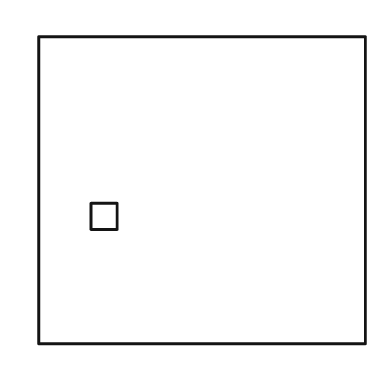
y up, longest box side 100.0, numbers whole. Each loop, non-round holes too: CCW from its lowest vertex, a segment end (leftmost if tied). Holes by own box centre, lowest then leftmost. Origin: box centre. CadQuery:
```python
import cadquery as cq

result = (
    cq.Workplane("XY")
    .moveTo(-50.0, -47.0)
    .lineTo(50.0, -47.0)
    .lineTo(50.0, 47.0)
    .lineTo(-50.0, 47.0)
    .close()
    .moveTo(-34.0, -12.0)
    .lineTo(-26.0, -12.0)
    .lineTo(-26.0, -4.0)
    .lineTo(-34.0, -4.0)
    .close()
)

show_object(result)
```